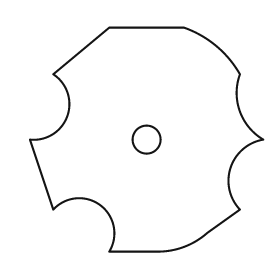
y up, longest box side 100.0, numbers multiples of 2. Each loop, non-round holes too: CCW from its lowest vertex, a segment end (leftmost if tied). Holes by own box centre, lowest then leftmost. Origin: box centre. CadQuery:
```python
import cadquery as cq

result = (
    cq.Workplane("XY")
    .moveTo(-16.0, -48.0)
    .lineTo(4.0, -48.0)
    .threePointArc((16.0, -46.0), (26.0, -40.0))
    .lineTo(40.0, -30.0)
    .threePointArc((36.0, -12.0), (50.0, 0.0))
    .threePointArc((40.0, 12.0), (40.0, 28.0))
    .threePointArc((30.0, 40.0), (16.0, 48.0))
    .lineTo(-16.0, 48.0)
    .lineTo(-40.0, 28.0)
    .threePointArc((-34.0, 10.0), (-50.0, 0.0))
    .lineTo(-40.0, -30.0)
    .threePointArc((-20.0, -28.0), (-16.0, -48.0))
    .close()
    .moveTo(0.0, 0.0)
    .circle(6.0)
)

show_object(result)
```